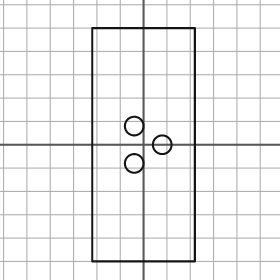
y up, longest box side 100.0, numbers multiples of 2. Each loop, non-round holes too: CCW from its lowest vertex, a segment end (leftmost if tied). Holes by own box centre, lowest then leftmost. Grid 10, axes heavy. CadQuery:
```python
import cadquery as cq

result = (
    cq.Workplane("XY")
    .moveTo(-22.0, -50.0)
    .lineTo(22.0, -50.0)
    .lineTo(22.0, 50.0)
    .lineTo(-22.0, 50.0)
    .close()
    .moveTo(-4.0, -8.0)
    .circle(4.0)
    .moveTo(8.0, 0.0)
    .circle(4.0)
    .moveTo(-4.0, 8.0)
    .circle(4.0)
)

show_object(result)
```